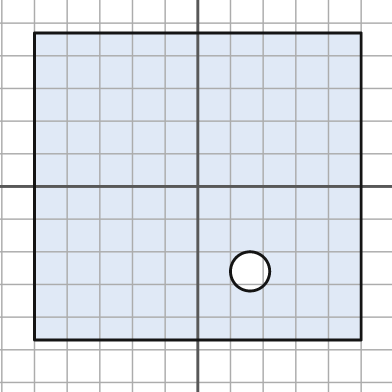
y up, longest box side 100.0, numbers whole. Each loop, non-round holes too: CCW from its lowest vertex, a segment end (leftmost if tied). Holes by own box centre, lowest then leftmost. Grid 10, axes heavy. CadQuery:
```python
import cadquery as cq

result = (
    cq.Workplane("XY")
    .moveTo(-50.0, -47.0)
    .lineTo(50.0, -47.0)
    .lineTo(50.0, 47.0)
    .lineTo(-50.0, 47.0)
    .close()
    .moveTo(16.0, -26.0)
    .circle(6.0)
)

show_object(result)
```